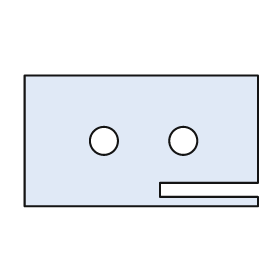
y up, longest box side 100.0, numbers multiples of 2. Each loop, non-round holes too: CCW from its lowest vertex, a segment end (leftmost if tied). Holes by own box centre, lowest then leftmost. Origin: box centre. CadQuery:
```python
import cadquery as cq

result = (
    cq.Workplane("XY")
    .moveTo(-50.0, -28.0)
    .lineTo(50.0, -28.0)
    .lineTo(50.0, -24.0)
    .lineTo(8.0, -24.0)
    .lineTo(8.0, -18.0)
    .lineTo(50.0, -18.0)
    .lineTo(50.0, 28.0)
    .lineTo(-50.0, 28.0)
    .close()
    .moveTo(-16.0, 0.0)
    .circle(6.0)
    .moveTo(18.0, 0.0)
    .circle(6.0)
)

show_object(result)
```